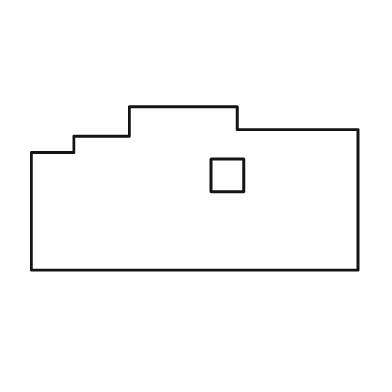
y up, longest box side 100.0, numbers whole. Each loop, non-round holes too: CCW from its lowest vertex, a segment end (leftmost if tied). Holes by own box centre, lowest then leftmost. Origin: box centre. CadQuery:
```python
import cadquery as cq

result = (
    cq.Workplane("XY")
    .moveTo(-50.0, -25.0)
    .lineTo(50.0, -25.0)
    .lineTo(50.0, 18.0)
    .lineTo(13.0, 18.0)
    .lineTo(13.0, 25.0)
    .lineTo(-20.0, 25.0)
    .lineTo(-20.0, 16.0)
    .lineTo(-37.0, 16.0)
    .lineTo(-37.0, 11.0)
    .lineTo(-50.0, 11.0)
    .close()
    .moveTo(5.0, -1.0)
    .lineTo(15.0, -1.0)
    .lineTo(15.0, 9.0)
    .lineTo(5.0, 9.0)
    .close()
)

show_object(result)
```